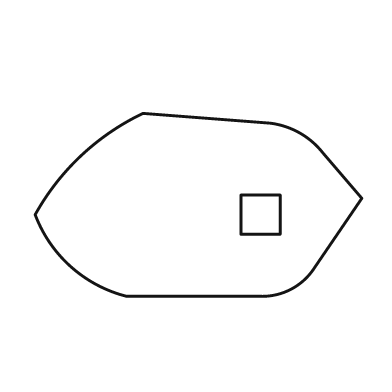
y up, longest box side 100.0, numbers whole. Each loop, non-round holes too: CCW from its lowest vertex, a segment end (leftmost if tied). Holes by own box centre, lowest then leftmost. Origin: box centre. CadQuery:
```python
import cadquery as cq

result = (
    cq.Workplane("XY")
    .moveTo(-22.0, -28.0)
    .lineTo(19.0, -28.0)
    .threePointArc((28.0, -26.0), (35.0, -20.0))
    .lineTo(50.0, 2.0)
    .lineTo(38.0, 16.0)
    .threePointArc((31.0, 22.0), (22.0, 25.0))
    .lineTo(-17.0, 28.0)
    .threePointArc((-36.0, 15.0), (-50.0, -3.0))
    .threePointArc((-39.0, -19.0), (-22.0, -28.0))
    .close()
    .moveTo(13.0, -9.0)
    .lineTo(25.0, -9.0)
    .lineTo(25.0, 3.0)
    .lineTo(13.0, 3.0)
    .close()
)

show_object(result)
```